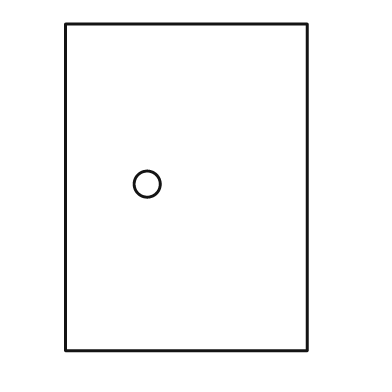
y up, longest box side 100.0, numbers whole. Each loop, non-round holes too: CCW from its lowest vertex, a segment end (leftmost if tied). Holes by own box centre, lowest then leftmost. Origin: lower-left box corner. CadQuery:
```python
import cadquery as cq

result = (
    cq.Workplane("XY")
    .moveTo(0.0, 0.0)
    .lineTo(74.0, 0.0)
    .lineTo(74.0, 100.0)
    .lineTo(0.0, 100.0)
    .close()
    .moveTo(25.0, 51.0)
    .circle(4.0)
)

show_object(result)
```